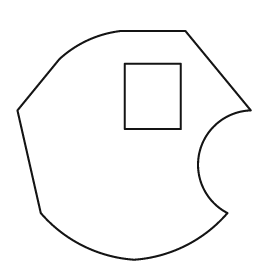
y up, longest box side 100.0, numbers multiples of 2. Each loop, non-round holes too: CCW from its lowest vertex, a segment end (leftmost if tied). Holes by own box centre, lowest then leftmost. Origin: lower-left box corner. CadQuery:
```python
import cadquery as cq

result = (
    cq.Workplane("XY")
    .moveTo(50.0, 0.0)
    .threePointArc((72.0, 6.0), (90.0, 20.0))
    .threePointArc((78.0, 46.0), (100.0, 64.0))
    .lineTo(72.0, 98.0)
    .lineTo(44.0, 98.0)
    .threePointArc((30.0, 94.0), (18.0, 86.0))
    .lineTo(0.0, 64.0)
    .lineTo(10.0, 20.0)
    .threePointArc((28.0, 6.0), (50.0, 0.0))
    .close()
    .moveTo(46.0, 56.0)
    .lineTo(70.0, 56.0)
    .lineTo(70.0, 84.0)
    .lineTo(46.0, 84.0)
    .close()
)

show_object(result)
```